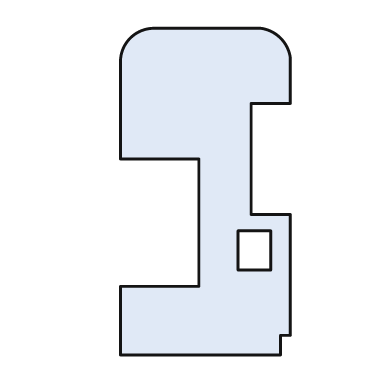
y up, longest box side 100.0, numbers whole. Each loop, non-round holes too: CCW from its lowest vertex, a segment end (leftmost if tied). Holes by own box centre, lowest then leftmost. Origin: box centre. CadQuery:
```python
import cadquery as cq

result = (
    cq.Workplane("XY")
    .moveTo(-26.0, -50.0)
    .lineTo(23.0, -50.0)
    .lineTo(23.0, -44.0)
    .lineTo(26.0, -44.0)
    .lineTo(26.0, -7.0)
    .lineTo(14.0, -7.0)
    .lineTo(14.0, 27.0)
    .lineTo(26.0, 27.0)
    .lineTo(26.0, 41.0)
    .threePointArc((23.0, 47.0), (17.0, 50.0))
    .lineTo(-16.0, 50.0)
    .threePointArc((-23.0, 47.0), (-26.0, 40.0))
    .lineTo(-26.0, 10.0)
    .lineTo(-2.0, 10.0)
    .lineTo(-2.0, -29.0)
    .lineTo(-26.0, -29.0)
    .close()
    .moveTo(10.0, -24.0)
    .lineTo(20.0, -24.0)
    .lineTo(20.0, -12.0)
    .lineTo(10.0, -12.0)
    .close()
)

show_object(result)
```